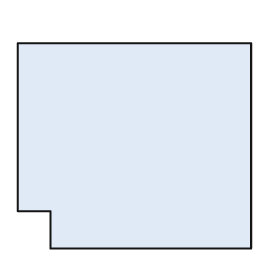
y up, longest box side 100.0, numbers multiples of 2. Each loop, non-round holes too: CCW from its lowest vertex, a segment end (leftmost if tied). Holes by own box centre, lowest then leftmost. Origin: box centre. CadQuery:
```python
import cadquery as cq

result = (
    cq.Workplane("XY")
    .moveTo(-36.0, -44.0)
    .lineTo(50.0, -44.0)
    .lineTo(50.0, 44.0)
    .lineTo(-50.0, 44.0)
    .lineTo(-50.0, -28.0)
    .lineTo(-36.0, -28.0)
    .close()
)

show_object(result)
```